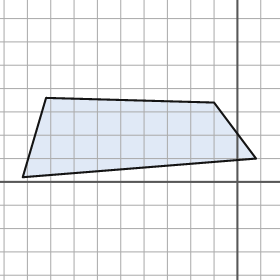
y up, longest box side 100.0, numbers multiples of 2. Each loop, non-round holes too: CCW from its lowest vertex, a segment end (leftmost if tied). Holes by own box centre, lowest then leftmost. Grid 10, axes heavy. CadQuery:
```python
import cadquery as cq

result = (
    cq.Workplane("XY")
    .moveTo(-92.0, 2.0)
    .lineTo(8.0, 10.0)
    .lineTo(-10.0, 34.0)
    .lineTo(-82.0, 36.0)
    .close()
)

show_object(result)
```